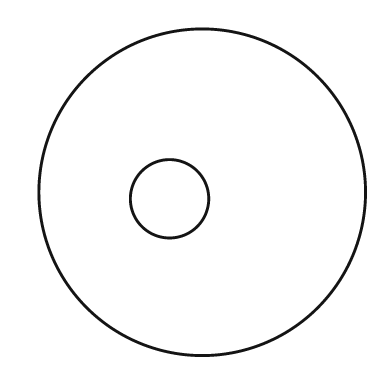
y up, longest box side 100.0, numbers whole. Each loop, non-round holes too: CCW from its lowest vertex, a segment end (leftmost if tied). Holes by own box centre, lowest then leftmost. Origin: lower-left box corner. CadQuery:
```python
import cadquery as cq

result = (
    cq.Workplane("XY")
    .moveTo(50.0, 50.0)
    .circle(50.0)
    .moveTo(40.0, 48.0)
    .circle(12.0)
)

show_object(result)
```